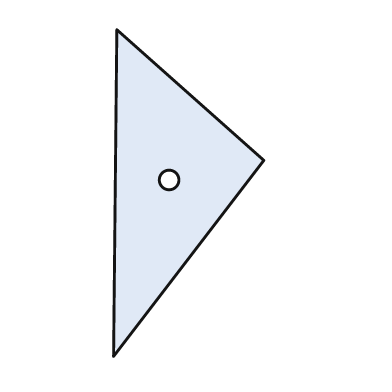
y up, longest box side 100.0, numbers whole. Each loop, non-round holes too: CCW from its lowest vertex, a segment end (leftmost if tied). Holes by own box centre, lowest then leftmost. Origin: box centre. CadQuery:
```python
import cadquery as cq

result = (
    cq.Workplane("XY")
    .moveTo(-23.0, -50.0)
    .lineTo(23.0, 10.0)
    .lineTo(-22.0, 50.0)
    .close()
    .moveTo(-6.0, 4.0)
    .circle(3.0)
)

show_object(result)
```